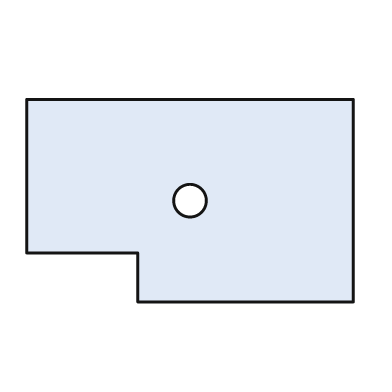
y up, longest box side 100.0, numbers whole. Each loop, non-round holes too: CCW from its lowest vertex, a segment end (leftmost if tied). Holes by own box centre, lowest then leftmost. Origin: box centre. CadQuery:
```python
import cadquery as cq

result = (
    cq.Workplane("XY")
    .moveTo(-16.0, -31.0)
    .lineTo(50.0, -31.0)
    .lineTo(50.0, 31.0)
    .lineTo(-50.0, 31.0)
    .lineTo(-50.0, -16.0)
    .lineTo(-16.0, -16.0)
    .close()
    .moveTo(0.0, 0.0)
    .circle(5.0)
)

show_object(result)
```